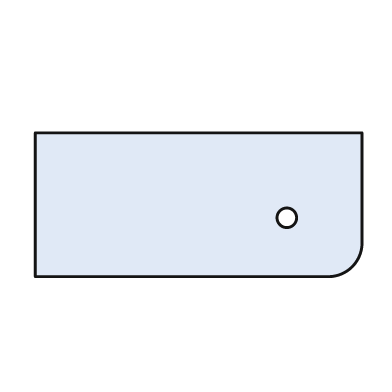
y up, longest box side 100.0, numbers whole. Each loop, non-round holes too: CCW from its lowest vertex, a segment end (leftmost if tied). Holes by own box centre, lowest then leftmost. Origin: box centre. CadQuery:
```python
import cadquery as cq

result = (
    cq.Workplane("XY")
    .moveTo(-50.0, -22.0)
    .lineTo(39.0, -22.0)
    .threePointArc((47.0, -19.0), (50.0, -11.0))
    .lineTo(50.0, 22.0)
    .lineTo(-50.0, 22.0)
    .close()
    .moveTo(27.0, -4.0)
    .circle(3.0)
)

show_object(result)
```